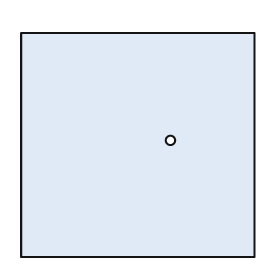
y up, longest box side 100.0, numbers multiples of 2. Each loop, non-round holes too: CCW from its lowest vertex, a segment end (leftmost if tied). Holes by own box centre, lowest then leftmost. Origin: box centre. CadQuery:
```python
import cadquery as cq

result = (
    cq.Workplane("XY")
    .moveTo(-50.0, -48.0)
    .lineTo(50.0, -48.0)
    .lineTo(50.0, 48.0)
    .lineTo(-50.0, 48.0)
    .close()
    .moveTo(14.0, 2.0)
    .circle(2.0)
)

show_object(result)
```